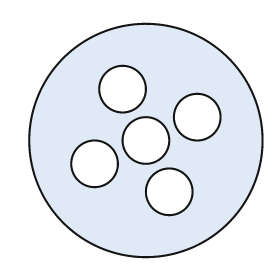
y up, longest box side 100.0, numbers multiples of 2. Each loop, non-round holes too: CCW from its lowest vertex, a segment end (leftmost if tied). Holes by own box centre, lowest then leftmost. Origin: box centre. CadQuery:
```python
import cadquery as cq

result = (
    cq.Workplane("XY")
    .moveTo(0.0, 0.0)
    .circle(50.0)
    .moveTo(10.0, -22.0)
    .circle(10.0)
    .moveTo(-22.0, -10.0)
    .circle(10.0)
    .moveTo(0.0, 0.0)
    .circle(10.0)
    .moveTo(22.0, 10.0)
    .circle(10.0)
    .moveTo(-10.0, 22.0)
    .circle(10.0)
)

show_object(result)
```